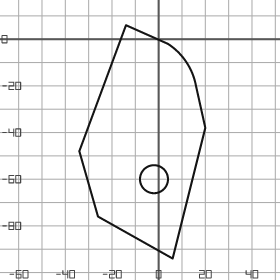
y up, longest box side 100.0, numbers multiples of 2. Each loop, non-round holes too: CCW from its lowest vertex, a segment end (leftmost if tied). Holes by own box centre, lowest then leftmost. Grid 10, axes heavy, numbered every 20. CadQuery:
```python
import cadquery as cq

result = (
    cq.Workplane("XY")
    .moveTo(6.0, -94.0)
    .lineTo(20.0, -38.0)
    .lineTo(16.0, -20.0)
    .threePointArc((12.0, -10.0), (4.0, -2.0))
    .lineTo(-14.0, 6.0)
    .lineTo(-34.0, -48.0)
    .lineTo(-26.0, -76.0)
    .close()
    .moveTo(-2.0, -60.0)
    .circle(6.0)
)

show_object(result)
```